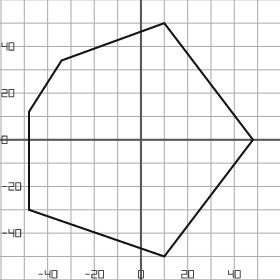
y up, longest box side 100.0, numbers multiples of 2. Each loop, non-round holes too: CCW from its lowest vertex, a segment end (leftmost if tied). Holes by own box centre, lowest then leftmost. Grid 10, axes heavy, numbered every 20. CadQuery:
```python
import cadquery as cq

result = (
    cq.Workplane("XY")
    .moveTo(10.0, -50.0)
    .lineTo(48.0, 0.0)
    .lineTo(10.0, 50.0)
    .lineTo(-34.0, 34.0)
    .lineTo(-48.0, 12.0)
    .lineTo(-48.0, -30.0)
    .close()
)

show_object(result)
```